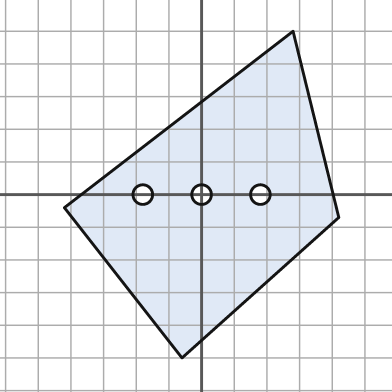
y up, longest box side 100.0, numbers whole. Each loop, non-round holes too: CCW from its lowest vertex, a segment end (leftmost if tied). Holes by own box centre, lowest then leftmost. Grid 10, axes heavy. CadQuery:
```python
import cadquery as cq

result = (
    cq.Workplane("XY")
    .moveTo(-6.0, -50.0)
    .lineTo(42.0, -7.0)
    .lineTo(28.0, 50.0)
    .lineTo(-42.0, -4.0)
    .close()
    .moveTo(-18.0, 0.0)
    .circle(3.0)
    .moveTo(0.0, 0.0)
    .circle(3.0)
    .moveTo(18.0, 0.0)
    .circle(3.0)
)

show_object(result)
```